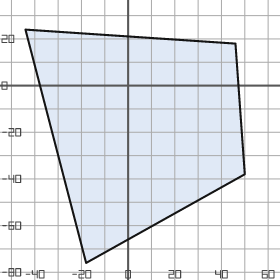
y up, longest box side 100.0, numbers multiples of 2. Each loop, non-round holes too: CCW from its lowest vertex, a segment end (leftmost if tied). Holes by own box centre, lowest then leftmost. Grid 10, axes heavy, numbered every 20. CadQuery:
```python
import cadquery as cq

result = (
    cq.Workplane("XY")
    .moveTo(-18.0, -76.0)
    .lineTo(50.0, -38.0)
    .lineTo(46.0, 18.0)
    .lineTo(-44.0, 24.0)
    .close()
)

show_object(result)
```